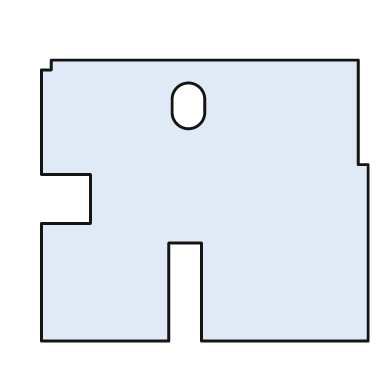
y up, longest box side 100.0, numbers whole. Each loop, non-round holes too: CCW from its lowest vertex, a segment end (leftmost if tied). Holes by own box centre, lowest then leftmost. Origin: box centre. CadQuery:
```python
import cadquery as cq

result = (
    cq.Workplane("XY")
    .moveTo(-50.0, -43.0)
    .lineTo(-11.0, -43.0)
    .lineTo(-11.0, -13.0)
    .lineTo(-1.0, -13.0)
    .lineTo(-1.0, -43.0)
    .lineTo(50.0, -43.0)
    .lineTo(50.0, 11.0)
    .lineTo(47.0, 11.0)
    .lineTo(47.0, 43.0)
    .lineTo(-47.0, 43.0)
    .lineTo(-47.0, 40.0)
    .lineTo(-50.0, 40.0)
    .lineTo(-50.0, 8.0)
    .lineTo(-35.0, 8.0)
    .lineTo(-35.0, -7.0)
    .lineTo(-50.0, -7.0)
    .close()
    .moveTo(-10.0, 27.0)
    .threePointArc((-5.0, 22.0), (0.0, 27.0))
    .lineTo(0.0, 31.0)
    .threePointArc((-5.0, 36.0), (-10.0, 31.0))
    .close()
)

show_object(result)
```